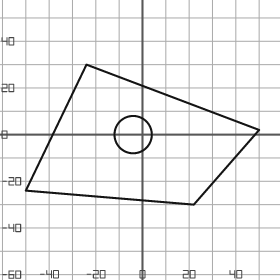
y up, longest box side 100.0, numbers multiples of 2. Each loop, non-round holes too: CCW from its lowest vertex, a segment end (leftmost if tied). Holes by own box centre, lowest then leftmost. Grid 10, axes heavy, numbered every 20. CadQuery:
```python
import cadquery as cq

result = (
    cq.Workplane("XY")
    .moveTo(22.0, -30.0)
    .lineTo(50.0, 2.0)
    .lineTo(-24.0, 30.0)
    .lineTo(-50.0, -24.0)
    .close()
    .moveTo(-4.0, 0.0)
    .circle(8.0)
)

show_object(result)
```